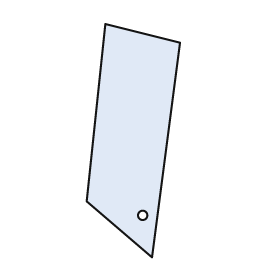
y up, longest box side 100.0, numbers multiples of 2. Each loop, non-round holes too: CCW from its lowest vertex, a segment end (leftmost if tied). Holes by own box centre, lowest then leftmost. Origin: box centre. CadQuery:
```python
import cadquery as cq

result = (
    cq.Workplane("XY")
    .moveTo(8.0, -50.0)
    .lineTo(20.0, 42.0)
    .lineTo(-12.0, 50.0)
    .lineTo(-20.0, -26.0)
    .close()
    .moveTo(4.0, -32.0)
    .circle(2.0)
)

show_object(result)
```